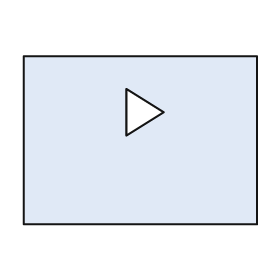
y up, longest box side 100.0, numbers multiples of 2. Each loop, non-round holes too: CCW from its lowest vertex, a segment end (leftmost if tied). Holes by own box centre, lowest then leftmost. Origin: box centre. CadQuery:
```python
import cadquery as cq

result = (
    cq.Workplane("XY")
    .moveTo(-50.0, -36.0)
    .lineTo(50.0, -36.0)
    .lineTo(50.0, 36.0)
    .lineTo(-50.0, 36.0)
    .close()
    .moveTo(-6.0, 2.0)
    .lineTo(10.0, 12.0)
    .lineTo(-6.0, 22.0)
    .close()
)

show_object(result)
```